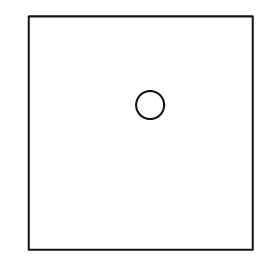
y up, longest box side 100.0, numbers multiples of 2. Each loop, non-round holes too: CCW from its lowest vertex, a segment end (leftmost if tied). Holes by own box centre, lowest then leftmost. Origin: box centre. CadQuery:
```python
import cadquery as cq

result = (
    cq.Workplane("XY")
    .moveTo(-48.0, -50.0)
    .lineTo(48.0, -50.0)
    .lineTo(48.0, 50.0)
    .lineTo(-48.0, 50.0)
    .close()
    .moveTo(4.0, 12.0)
    .circle(6.0)
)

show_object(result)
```